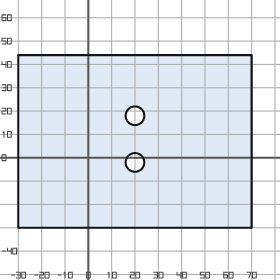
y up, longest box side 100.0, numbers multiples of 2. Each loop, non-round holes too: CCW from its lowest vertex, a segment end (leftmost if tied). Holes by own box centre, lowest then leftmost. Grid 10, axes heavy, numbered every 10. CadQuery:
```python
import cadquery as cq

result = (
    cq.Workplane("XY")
    .moveTo(-30.0, -30.0)
    .lineTo(70.0, -30.0)
    .lineTo(70.0, 44.0)
    .lineTo(-30.0, 44.0)
    .close()
    .moveTo(20.0, -2.0)
    .circle(4.0)
    .moveTo(20.0, 18.0)
    .circle(4.0)
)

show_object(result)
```